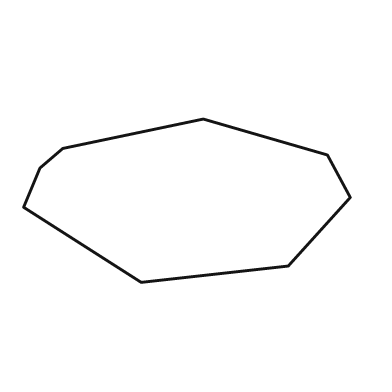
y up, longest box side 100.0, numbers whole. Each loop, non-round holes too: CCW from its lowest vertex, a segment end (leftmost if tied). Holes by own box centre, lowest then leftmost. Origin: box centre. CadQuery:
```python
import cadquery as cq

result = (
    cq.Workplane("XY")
    .moveTo(-14.0, -25.0)
    .lineTo(31.0, -20.0)
    .lineTo(50.0, 1.0)
    .lineTo(43.0, 14.0)
    .lineTo(5.0, 25.0)
    .lineTo(-38.0, 16.0)
    .lineTo(-45.0, 10.0)
    .lineTo(-50.0, -2.0)
    .close()
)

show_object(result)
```